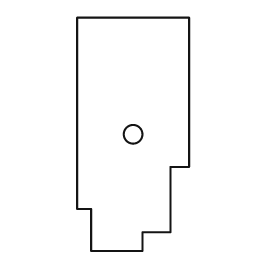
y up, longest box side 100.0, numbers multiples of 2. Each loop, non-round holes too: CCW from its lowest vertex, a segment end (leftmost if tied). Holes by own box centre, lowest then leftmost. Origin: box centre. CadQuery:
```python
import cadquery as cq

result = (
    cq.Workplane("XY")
    .moveTo(-18.0, -50.0)
    .lineTo(4.0, -50.0)
    .lineTo(4.0, -42.0)
    .lineTo(16.0, -42.0)
    .lineTo(16.0, -14.0)
    .lineTo(24.0, -14.0)
    .lineTo(24.0, 50.0)
    .lineTo(-24.0, 50.0)
    .lineTo(-24.0, -32.0)
    .lineTo(-18.0, -32.0)
    .close()
    .moveTo(0.0, 0.0)
    .circle(4.0)
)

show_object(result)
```